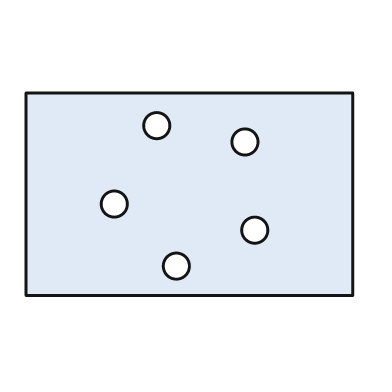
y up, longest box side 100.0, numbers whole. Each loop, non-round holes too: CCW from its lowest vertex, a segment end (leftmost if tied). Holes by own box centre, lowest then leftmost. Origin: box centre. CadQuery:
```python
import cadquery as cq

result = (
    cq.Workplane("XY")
    .moveTo(-50.0, -31.0)
    .lineTo(50.0, -31.0)
    .lineTo(50.0, 31.0)
    .lineTo(-50.0, 31.0)
    .close()
    .moveTo(-4.0, -22.0)
    .circle(4.0)
    .moveTo(20.0, -11.0)
    .circle(4.0)
    .moveTo(-23.0, -3.0)
    .circle(4.0)
    .moveTo(17.0, 16.0)
    .circle(4.0)
    .moveTo(-10.0, 21.0)
    .circle(4.0)
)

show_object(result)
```